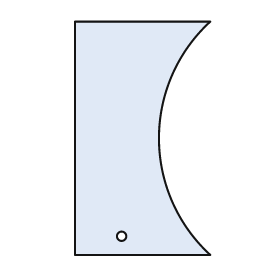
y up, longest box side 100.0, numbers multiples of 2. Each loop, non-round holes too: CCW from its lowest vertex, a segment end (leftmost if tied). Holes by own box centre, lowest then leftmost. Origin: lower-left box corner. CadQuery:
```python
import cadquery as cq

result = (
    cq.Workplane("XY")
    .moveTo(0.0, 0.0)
    .lineTo(58.0, 0.0)
    .threePointArc((36.0, 50.0), (58.0, 100.0))
    .lineTo(0.0, 100.0)
    .close()
    .moveTo(20.0, 8.0)
    .circle(2.0)
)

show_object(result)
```